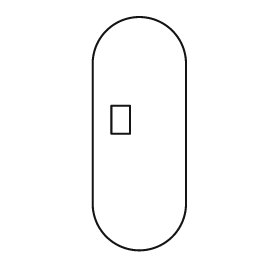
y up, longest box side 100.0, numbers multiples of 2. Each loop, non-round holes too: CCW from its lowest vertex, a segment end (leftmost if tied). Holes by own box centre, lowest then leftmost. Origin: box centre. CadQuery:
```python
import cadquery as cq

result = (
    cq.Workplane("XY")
    .moveTo(-20.0, -30.0)
    .threePointArc((0.0, -50.0), (20.0, -30.0))
    .lineTo(20.0, 30.0)
    .threePointArc((0.0, 50.0), (-20.0, 30.0))
    .close()
    .moveTo(-12.0, 0.0)
    .lineTo(-4.0, 0.0)
    .lineTo(-4.0, 12.0)
    .lineTo(-12.0, 12.0)
    .close()
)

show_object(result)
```